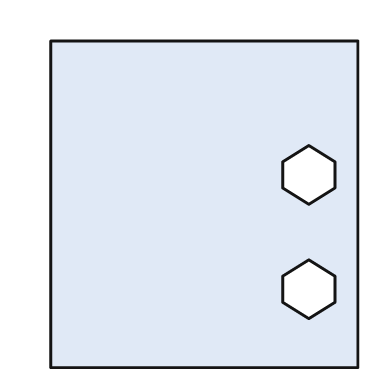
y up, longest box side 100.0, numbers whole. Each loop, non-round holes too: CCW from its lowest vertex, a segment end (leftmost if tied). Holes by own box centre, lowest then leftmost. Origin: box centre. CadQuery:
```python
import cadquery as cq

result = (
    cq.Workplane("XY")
    .moveTo(-47.0, -50.0)
    .lineTo(47.0, -50.0)
    .lineTo(47.0, 50.0)
    .lineTo(-47.0, 50.0)
    .close()
    .moveTo(32.0, -35.0)
    .lineTo(40.0, -30.0)
    .lineTo(40.0, -22.0)
    .lineTo(32.0, -17.0)
    .lineTo(24.0, -22.0)
    .lineTo(24.0, -30.0)
    .close()
    .moveTo(32.0, 0.0)
    .lineTo(40.0, 5.0)
    .lineTo(40.0, 13.0)
    .lineTo(32.0, 18.0)
    .lineTo(24.0, 13.0)
    .lineTo(24.0, 5.0)
    .close()
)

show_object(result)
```